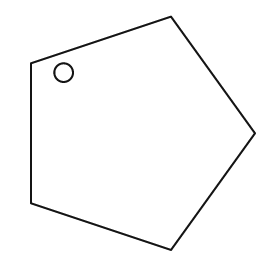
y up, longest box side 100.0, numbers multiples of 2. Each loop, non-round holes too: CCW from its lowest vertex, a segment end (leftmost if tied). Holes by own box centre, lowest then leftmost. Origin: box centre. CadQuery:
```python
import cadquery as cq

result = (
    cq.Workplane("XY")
    .moveTo(12.0, -50.0)
    .lineTo(48.0, 0.0)
    .lineTo(12.0, 50.0)
    .lineTo(-48.0, 30.0)
    .lineTo(-48.0, -30.0)
    .close()
    .moveTo(-34.0, 26.0)
    .circle(4.0)
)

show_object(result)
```